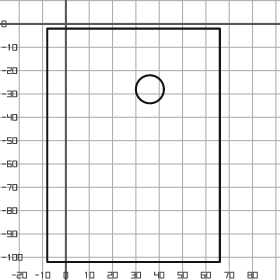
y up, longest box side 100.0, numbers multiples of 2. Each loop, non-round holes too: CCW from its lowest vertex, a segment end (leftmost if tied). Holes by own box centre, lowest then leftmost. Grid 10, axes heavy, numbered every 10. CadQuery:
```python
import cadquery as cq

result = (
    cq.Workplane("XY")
    .moveTo(-8.0, -102.0)
    .lineTo(66.0, -102.0)
    .lineTo(66.0, -2.0)
    .lineTo(-8.0, -2.0)
    .close()
    .moveTo(36.0, -28.0)
    .circle(6.0)
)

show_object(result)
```